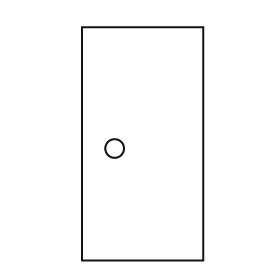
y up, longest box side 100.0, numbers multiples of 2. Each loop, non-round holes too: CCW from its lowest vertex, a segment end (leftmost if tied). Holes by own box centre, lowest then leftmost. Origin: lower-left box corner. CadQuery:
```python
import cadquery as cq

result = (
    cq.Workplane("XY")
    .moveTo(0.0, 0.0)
    .lineTo(52.0, 0.0)
    .lineTo(52.0, 100.0)
    .lineTo(0.0, 100.0)
    .close()
    .moveTo(14.0, 48.0)
    .circle(4.0)
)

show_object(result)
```